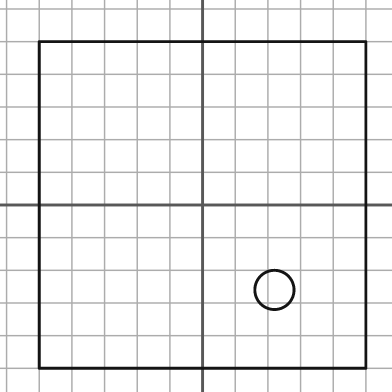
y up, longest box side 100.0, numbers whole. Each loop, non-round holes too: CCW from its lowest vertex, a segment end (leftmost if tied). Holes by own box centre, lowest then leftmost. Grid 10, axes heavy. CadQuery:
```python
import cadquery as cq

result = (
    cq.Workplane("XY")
    .moveTo(-50.0, -50.0)
    .lineTo(50.0, -50.0)
    .lineTo(50.0, 50.0)
    .lineTo(-50.0, 50.0)
    .close()
    .moveTo(22.0, -26.0)
    .circle(6.0)
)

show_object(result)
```